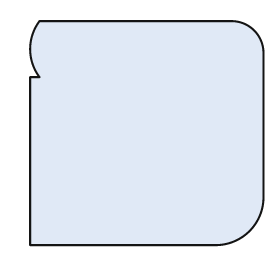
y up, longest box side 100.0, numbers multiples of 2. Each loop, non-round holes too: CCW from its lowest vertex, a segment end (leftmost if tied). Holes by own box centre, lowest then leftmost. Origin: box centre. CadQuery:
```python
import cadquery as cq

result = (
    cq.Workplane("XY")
    .moveTo(-50.0, -48.0)
    .lineTo(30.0, -48.0)
    .threePointArc((44.0, -42.0), (50.0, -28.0))
    .lineTo(50.0, 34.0)
    .threePointArc((46.0, 44.0), (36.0, 48.0))
    .lineTo(-46.0, 48.0)
    .threePointArc((-50.0, 36.0), (-46.0, 24.0))
    .lineTo(-50.0, 24.0)
    .close()
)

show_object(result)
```